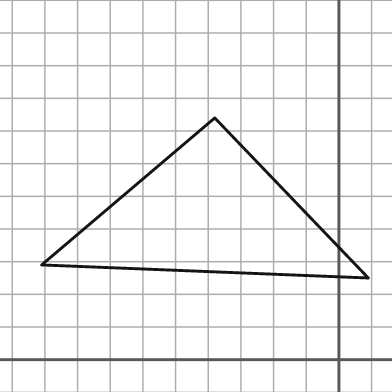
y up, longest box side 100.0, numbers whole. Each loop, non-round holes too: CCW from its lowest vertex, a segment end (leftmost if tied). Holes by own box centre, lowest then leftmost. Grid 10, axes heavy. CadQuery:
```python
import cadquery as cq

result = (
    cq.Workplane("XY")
    .moveTo(9.0, 25.0)
    .lineTo(-38.0, 74.0)
    .lineTo(-91.0, 29.0)
    .close()
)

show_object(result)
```